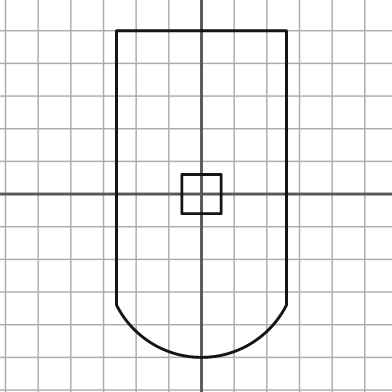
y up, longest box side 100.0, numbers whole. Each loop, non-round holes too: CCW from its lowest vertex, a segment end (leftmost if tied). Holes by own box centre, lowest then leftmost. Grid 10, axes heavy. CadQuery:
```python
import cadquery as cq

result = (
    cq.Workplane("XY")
    .moveTo(-26.0, -34.0)
    .threePointArc((0.0, -50.0), (26.0, -34.0))
    .lineTo(26.0, 50.0)
    .lineTo(-26.0, 50.0)
    .close()
    .moveTo(-6.0, -6.0)
    .lineTo(6.0, -6.0)
    .lineTo(6.0, 6.0)
    .lineTo(-6.0, 6.0)
    .close()
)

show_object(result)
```